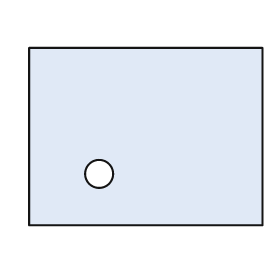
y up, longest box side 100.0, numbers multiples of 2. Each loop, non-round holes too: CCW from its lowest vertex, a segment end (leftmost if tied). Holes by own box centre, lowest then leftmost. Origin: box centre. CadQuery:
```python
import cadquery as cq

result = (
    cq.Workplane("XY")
    .moveTo(-50.0, -38.0)
    .lineTo(50.0, -38.0)
    .lineTo(50.0, 38.0)
    .lineTo(-50.0, 38.0)
    .close()
    .moveTo(-20.0, -16.0)
    .circle(6.0)
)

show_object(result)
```